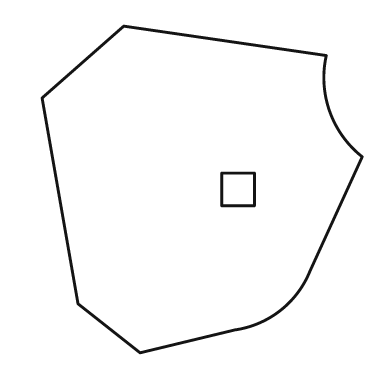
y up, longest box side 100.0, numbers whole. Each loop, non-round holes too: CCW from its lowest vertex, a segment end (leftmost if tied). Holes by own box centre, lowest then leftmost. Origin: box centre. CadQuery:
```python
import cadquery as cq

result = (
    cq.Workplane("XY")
    .moveTo(-19.0, -50.0)
    .lineTo(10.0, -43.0)
    .threePointArc((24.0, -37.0), (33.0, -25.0))
    .lineTo(49.0, 10.0)
    .threePointArc((39.0, 24.0), (38.0, 41.0))
    .lineTo(-24.0, 50.0)
    .lineTo(-49.0, 28.0)
    .lineTo(-38.0, -35.0)
    .close()
    .moveTo(6.0, -5.0)
    .lineTo(16.0, -5.0)
    .lineTo(16.0, 5.0)
    .lineTo(6.0, 5.0)
    .close()
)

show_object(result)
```